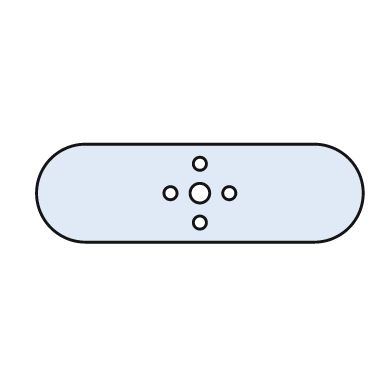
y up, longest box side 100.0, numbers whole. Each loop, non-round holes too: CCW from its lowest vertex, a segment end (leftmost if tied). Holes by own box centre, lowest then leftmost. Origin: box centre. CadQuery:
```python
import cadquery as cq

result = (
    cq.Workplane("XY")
    .moveTo(-35.0, -15.0)
    .lineTo(35.0, -15.0)
    .threePointArc((50.0, 0.0), (35.0, 15.0))
    .lineTo(-35.0, 15.0)
    .threePointArc((-50.0, 0.0), (-35.0, -15.0))
    .close()
    .moveTo(0.0, -9.0)
    .circle(2.0)
    .moveTo(-9.0, 0.0)
    .circle(2.0)
    .moveTo(0.0, 0.0)
    .circle(3.0)
    .moveTo(9.0, 0.0)
    .circle(2.0)
    .moveTo(0.0, 9.0)
    .circle(2.0)
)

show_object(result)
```